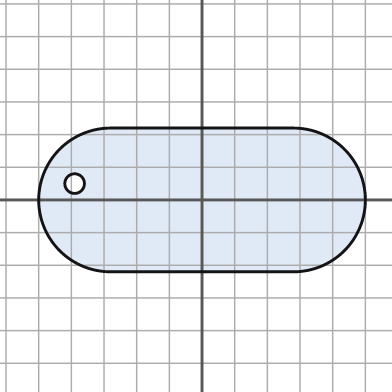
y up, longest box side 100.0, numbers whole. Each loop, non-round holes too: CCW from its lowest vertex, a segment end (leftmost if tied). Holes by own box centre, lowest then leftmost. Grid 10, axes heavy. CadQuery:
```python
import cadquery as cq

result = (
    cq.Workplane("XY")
    .moveTo(-28.0, -22.0)
    .lineTo(28.0, -22.0)
    .threePointArc((50.0, 0.0), (28.0, 22.0))
    .lineTo(-28.0, 22.0)
    .threePointArc((-50.0, 0.0), (-28.0, -22.0))
    .close()
    .moveTo(-39.0, 5.0)
    .circle(3.0)
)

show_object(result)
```